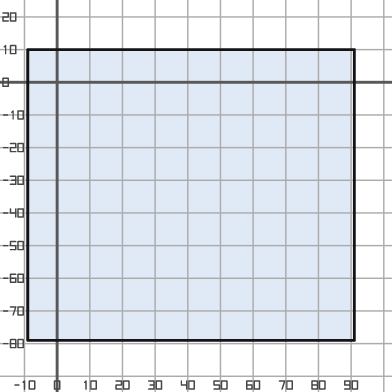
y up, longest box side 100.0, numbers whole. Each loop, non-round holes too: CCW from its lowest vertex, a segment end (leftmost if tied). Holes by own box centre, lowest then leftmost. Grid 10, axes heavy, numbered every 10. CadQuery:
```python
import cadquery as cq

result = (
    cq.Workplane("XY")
    .moveTo(-9.0, -79.0)
    .lineTo(91.0, -79.0)
    .lineTo(91.0, 10.0)
    .lineTo(-9.0, 10.0)
    .close()
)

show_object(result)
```